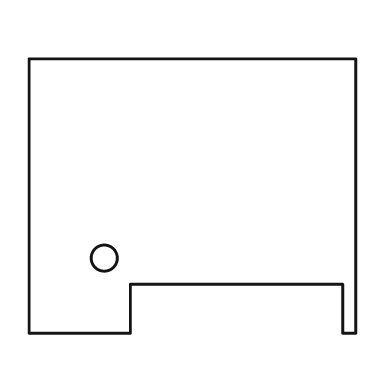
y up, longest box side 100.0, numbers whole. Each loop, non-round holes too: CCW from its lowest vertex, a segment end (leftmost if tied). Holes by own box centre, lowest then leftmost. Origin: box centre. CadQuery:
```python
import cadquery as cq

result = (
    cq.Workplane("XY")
    .moveTo(-50.0, -42.0)
    .lineTo(-19.0, -42.0)
    .lineTo(-19.0, -27.0)
    .lineTo(46.0, -27.0)
    .lineTo(46.0, -42.0)
    .lineTo(50.0, -42.0)
    .lineTo(50.0, 42.0)
    .lineTo(-50.0, 42.0)
    .close()
    .moveTo(-27.0, -19.0)
    .circle(4.0)
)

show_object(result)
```